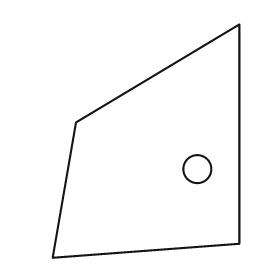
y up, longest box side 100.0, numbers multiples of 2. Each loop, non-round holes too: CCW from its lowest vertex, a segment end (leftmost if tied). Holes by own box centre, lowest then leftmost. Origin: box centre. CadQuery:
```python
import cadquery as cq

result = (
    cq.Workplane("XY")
    .moveTo(-40.0, -50.0)
    .lineTo(40.0, -44.0)
    .lineTo(40.0, 50.0)
    .lineTo(-30.0, 8.0)
    .close()
    .moveTo(22.0, -12.0)
    .circle(6.0)
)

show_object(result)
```